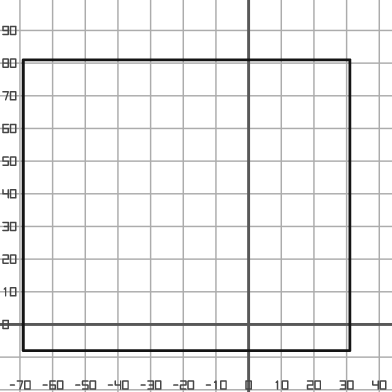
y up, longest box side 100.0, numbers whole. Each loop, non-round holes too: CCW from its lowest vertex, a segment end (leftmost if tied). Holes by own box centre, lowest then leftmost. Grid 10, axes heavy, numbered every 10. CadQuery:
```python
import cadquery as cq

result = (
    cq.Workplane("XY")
    .moveTo(-69.0, -8.0)
    .lineTo(31.0, -8.0)
    .lineTo(31.0, 81.0)
    .lineTo(-69.0, 81.0)
    .close()
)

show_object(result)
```